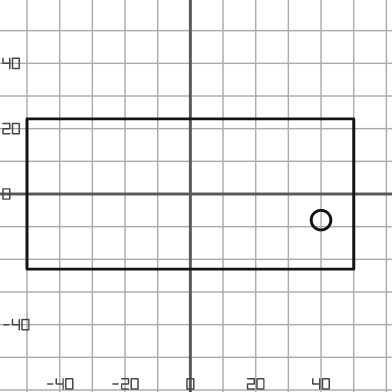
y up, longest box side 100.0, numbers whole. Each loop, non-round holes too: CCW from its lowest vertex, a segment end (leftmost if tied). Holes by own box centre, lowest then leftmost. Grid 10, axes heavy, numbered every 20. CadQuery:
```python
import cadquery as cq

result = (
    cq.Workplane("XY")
    .moveTo(-50.0, -23.0)
    .lineTo(50.0, -23.0)
    .lineTo(50.0, 23.0)
    .lineTo(-50.0, 23.0)
    .close()
    .moveTo(40.0, -8.0)
    .circle(3.0)
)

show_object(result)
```